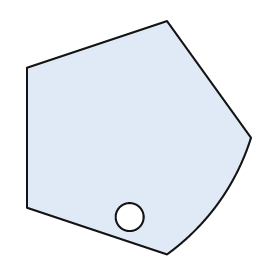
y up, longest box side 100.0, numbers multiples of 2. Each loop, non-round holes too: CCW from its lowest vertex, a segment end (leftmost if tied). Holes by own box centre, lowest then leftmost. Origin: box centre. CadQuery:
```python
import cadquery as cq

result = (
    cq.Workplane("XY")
    .moveTo(12.0, -50.0)
    .threePointArc((34.0, -28.0), (48.0, 0.0))
    .lineTo(12.0, 50.0)
    .lineTo(-48.0, 30.0)
    .lineTo(-48.0, -30.0)
    .close()
    .moveTo(-4.0, -34.0)
    .circle(6.0)
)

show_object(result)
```